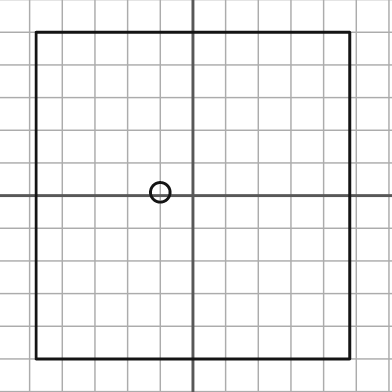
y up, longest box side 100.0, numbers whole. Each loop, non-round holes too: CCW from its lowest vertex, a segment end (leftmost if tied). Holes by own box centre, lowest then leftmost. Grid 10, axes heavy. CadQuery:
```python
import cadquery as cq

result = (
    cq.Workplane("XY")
    .moveTo(-48.0, -50.0)
    .lineTo(48.0, -50.0)
    .lineTo(48.0, 50.0)
    .lineTo(-48.0, 50.0)
    .close()
    .moveTo(-10.0, 1.0)
    .circle(3.0)
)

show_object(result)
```